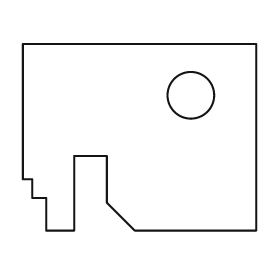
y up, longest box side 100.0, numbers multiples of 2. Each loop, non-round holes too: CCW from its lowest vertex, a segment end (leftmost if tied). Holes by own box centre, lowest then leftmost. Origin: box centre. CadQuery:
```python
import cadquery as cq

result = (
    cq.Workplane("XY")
    .moveTo(-40.0, -40.0)
    .lineTo(-28.0, -40.0)
    .lineTo(-28.0, -8.0)
    .lineTo(-14.0, -8.0)
    .lineTo(-14.0, -28.0)
    .lineTo(-2.0, -40.0)
    .lineTo(50.0, -40.0)
    .lineTo(50.0, 40.0)
    .lineTo(-50.0, 40.0)
    .lineTo(-50.0, -18.0)
    .lineTo(-46.0, -18.0)
    .lineTo(-46.0, -26.0)
    .lineTo(-40.0, -26.0)
    .close()
    .moveTo(22.0, 18.0)
    .circle(10.0)
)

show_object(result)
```